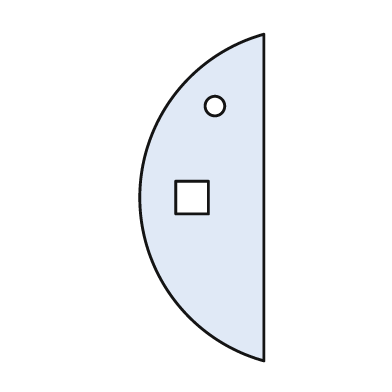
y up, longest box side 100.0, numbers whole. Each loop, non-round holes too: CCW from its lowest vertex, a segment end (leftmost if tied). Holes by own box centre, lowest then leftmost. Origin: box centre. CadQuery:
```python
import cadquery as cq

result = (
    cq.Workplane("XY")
    .moveTo(19.0, -50.0)
    .lineTo(19.0, 50.0)
    .threePointArc((-19.0, 0.0), (19.0, -50.0))
    .close()
    .moveTo(-8.0, -5.0)
    .lineTo(2.0, -5.0)
    .lineTo(2.0, 5.0)
    .lineTo(-8.0, 5.0)
    .close()
    .moveTo(4.0, 28.0)
    .circle(3.0)
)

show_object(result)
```